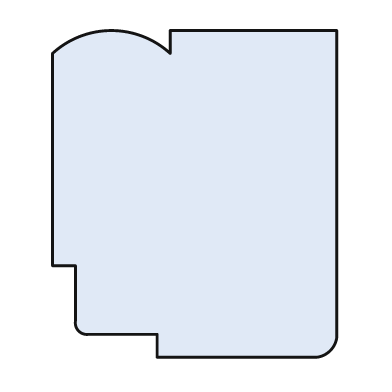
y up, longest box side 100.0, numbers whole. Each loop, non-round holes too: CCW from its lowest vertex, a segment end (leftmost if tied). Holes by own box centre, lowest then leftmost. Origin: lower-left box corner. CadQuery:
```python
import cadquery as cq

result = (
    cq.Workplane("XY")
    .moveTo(32.0, 0.0)
    .lineTo(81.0, 0.0)
    .threePointArc((85.0, 2.0), (87.0, 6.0))
    .lineTo(87.0, 100.0)
    .lineTo(36.0, 100.0)
    .lineTo(36.0, 93.0)
    .threePointArc((18.0, 100.0), (0.0, 93.0))
    .lineTo(0.0, 28.0)
    .lineTo(7.0, 28.0)
    .lineTo(7.0, 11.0)
    .threePointArc((8.0, 8.0), (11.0, 7.0))
    .lineTo(32.0, 7.0)
    .close()
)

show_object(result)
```